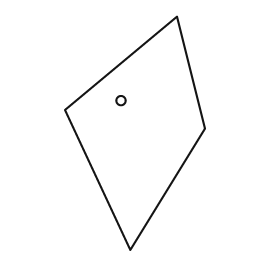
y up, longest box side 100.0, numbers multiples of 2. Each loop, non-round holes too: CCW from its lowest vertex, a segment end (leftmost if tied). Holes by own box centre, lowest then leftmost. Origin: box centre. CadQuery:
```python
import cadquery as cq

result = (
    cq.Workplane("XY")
    .moveTo(-2.0, -50.0)
    .lineTo(30.0, 2.0)
    .lineTo(18.0, 50.0)
    .lineTo(-30.0, 10.0)
    .close()
    .moveTo(-6.0, 14.0)
    .circle(2.0)
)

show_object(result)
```